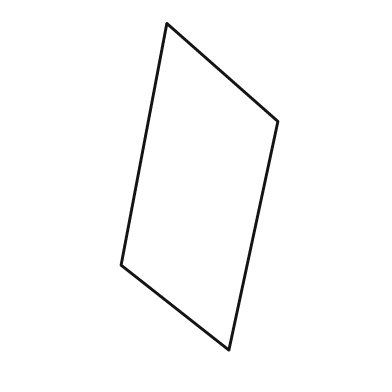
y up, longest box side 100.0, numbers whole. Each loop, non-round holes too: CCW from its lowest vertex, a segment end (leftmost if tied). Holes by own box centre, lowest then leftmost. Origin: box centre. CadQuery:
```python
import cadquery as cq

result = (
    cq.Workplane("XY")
    .moveTo(9.0, -50.0)
    .lineTo(24.0, 20.0)
    .lineTo(-10.0, 50.0)
    .lineTo(-24.0, -24.0)
    .close()
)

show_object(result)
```